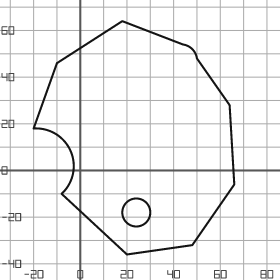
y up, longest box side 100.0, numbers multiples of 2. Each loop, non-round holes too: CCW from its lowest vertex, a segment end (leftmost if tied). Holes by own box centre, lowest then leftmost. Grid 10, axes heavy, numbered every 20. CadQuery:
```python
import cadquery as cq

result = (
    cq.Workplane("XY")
    .moveTo(20.0, -36.0)
    .lineTo(48.0, -32.0)
    .lineTo(66.0, -6.0)
    .lineTo(64.0, 28.0)
    .lineTo(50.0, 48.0)
    .threePointArc((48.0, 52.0), (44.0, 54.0))
    .lineTo(18.0, 64.0)
    .lineTo(-10.0, 46.0)
    .lineTo(-20.0, 18.0)
    .threePointArc((-4.0, 8.0), (-8.0, -10.0))
    .close()
    .moveTo(24.0, -18.0)
    .circle(6.0)
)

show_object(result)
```